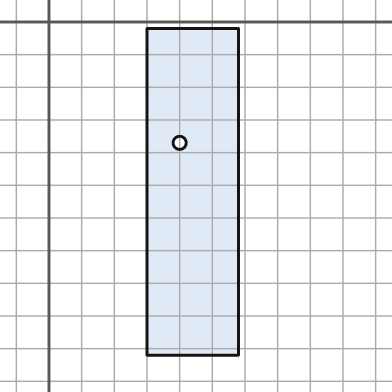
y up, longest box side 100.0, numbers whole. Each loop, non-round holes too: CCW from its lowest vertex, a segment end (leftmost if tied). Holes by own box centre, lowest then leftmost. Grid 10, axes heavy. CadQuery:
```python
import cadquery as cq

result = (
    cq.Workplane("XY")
    .moveTo(30.0, -102.0)
    .lineTo(58.0, -102.0)
    .lineTo(58.0, -2.0)
    .lineTo(30.0, -2.0)
    .close()
    .moveTo(40.0, -37.0)
    .circle(2.0)
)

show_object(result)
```